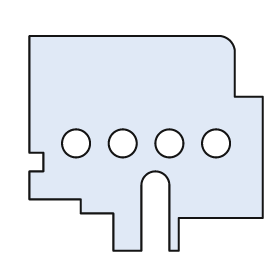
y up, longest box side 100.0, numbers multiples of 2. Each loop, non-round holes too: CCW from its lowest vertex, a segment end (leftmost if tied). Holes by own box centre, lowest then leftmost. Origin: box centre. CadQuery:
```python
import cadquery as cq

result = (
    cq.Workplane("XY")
    .moveTo(-14.0, -46.0)
    .lineTo(-2.0, -46.0)
    .lineTo(-2.0, -18.0)
    .threePointArc((4.0, -12.0), (10.0, -18.0))
    .lineTo(10.0, -46.0)
    .lineTo(14.0, -46.0)
    .lineTo(14.0, -32.0)
    .lineTo(50.0, -32.0)
    .lineTo(50.0, 20.0)
    .lineTo(38.0, 20.0)
    .lineTo(38.0, 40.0)
    .threePointArc((36.0, 44.0), (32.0, 46.0))
    .lineTo(-50.0, 46.0)
    .lineTo(-50.0, -4.0)
    .lineTo(-44.0, -4.0)
    .lineTo(-44.0, -12.0)
    .lineTo(-50.0, -12.0)
    .lineTo(-50.0, -24.0)
    .lineTo(-28.0, -24.0)
    .lineTo(-28.0, -30.0)
    .lineTo(-14.0, -30.0)
    .close()
    .moveTo(-30.0, 0.0)
    .circle(6.0)
    .moveTo(-10.0, 0.0)
    .circle(6.0)
    .moveTo(10.0, 0.0)
    .circle(6.0)
    .moveTo(30.0, 0.0)
    .circle(6.0)
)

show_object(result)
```